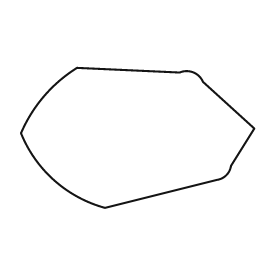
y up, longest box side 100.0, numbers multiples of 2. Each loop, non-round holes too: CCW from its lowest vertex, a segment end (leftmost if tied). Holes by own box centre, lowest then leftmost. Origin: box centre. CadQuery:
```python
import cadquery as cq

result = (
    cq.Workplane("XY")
    .moveTo(-14.0, -30.0)
    .lineTo(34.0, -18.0)
    .threePointArc((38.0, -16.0), (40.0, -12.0))
    .lineTo(50.0, 4.0)
    .lineTo(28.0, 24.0)
    .threePointArc((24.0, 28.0), (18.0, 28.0))
    .lineTo(-26.0, 30.0)
    .threePointArc((-40.0, 18.0), (-50.0, 2.0))
    .threePointArc((-36.0, -18.0), (-14.0, -30.0))
    .close()
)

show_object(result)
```